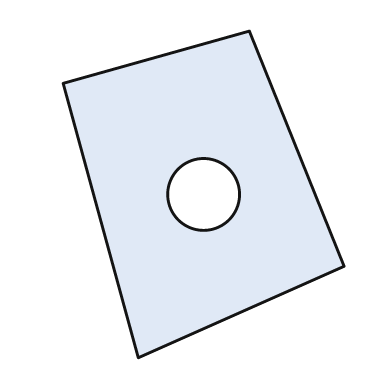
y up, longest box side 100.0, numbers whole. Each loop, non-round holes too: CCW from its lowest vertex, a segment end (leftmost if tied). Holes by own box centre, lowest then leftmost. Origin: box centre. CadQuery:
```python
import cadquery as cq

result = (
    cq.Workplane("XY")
    .moveTo(-20.0, -50.0)
    .lineTo(43.0, -22.0)
    .lineTo(14.0, 50.0)
    .lineTo(-43.0, 34.0)
    .close()
    .moveTo(0.0, 0.0)
    .circle(11.0)
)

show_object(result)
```